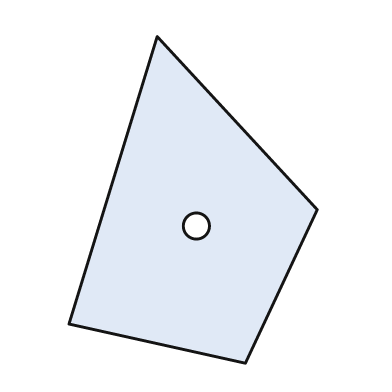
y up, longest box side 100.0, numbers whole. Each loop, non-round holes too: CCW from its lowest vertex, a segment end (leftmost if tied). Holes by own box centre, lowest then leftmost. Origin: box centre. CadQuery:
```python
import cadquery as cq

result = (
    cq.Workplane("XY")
    .moveTo(16.0, -50.0)
    .lineTo(38.0, -3.0)
    .lineTo(-11.0, 50.0)
    .lineTo(-38.0, -38.0)
    .close()
    .moveTo(1.0, -8.0)
    .circle(4.0)
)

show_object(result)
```